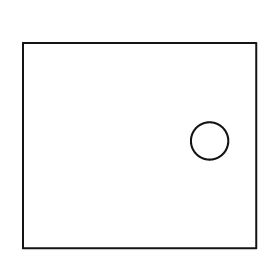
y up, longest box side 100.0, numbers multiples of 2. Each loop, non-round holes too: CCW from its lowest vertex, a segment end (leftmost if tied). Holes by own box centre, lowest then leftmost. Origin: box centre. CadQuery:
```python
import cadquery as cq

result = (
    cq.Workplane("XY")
    .moveTo(-50.0, -44.0)
    .lineTo(50.0, -44.0)
    .lineTo(50.0, 44.0)
    .lineTo(-50.0, 44.0)
    .close()
    .moveTo(30.0, 2.0)
    .circle(8.0)
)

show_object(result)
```